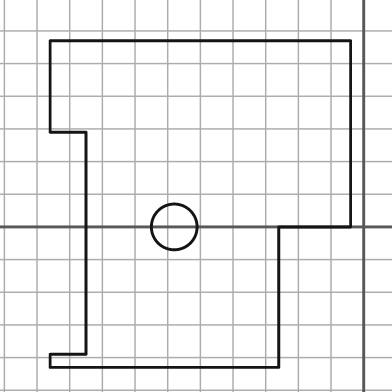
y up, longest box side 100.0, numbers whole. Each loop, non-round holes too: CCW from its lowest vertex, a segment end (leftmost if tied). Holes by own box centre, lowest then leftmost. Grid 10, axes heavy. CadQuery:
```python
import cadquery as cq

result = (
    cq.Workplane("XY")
    .moveTo(-96.0, -43.0)
    .lineTo(-26.0, -43.0)
    .lineTo(-26.0, 0.0)
    .lineTo(-4.0, 0.0)
    .lineTo(-4.0, 57.0)
    .lineTo(-96.0, 57.0)
    .lineTo(-96.0, 29.0)
    .lineTo(-85.0, 29.0)
    .lineTo(-85.0, -39.0)
    .lineTo(-96.0, -39.0)
    .close()
    .moveTo(-58.0, 0.0)
    .circle(7.0)
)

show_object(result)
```